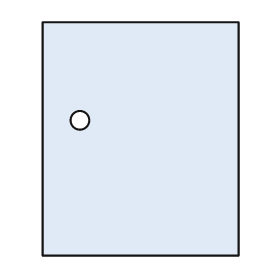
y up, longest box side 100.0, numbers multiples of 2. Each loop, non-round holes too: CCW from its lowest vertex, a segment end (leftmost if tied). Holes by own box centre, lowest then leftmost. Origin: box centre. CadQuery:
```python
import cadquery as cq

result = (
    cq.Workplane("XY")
    .moveTo(-42.0, -50.0)
    .lineTo(42.0, -50.0)
    .lineTo(42.0, 50.0)
    .lineTo(-42.0, 50.0)
    .close()
    .moveTo(-26.0, 8.0)
    .circle(4.0)
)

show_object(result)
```